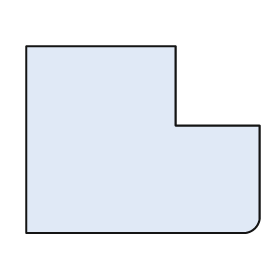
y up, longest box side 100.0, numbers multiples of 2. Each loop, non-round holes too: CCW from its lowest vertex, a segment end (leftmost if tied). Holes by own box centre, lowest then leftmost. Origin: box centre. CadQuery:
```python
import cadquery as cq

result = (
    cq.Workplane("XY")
    .moveTo(-50.0, -40.0)
    .lineTo(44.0, -40.0)
    .threePointArc((48.0, -38.0), (50.0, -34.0))
    .lineTo(50.0, 6.0)
    .lineTo(14.0, 6.0)
    .lineTo(14.0, 40.0)
    .lineTo(-50.0, 40.0)
    .close()
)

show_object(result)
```